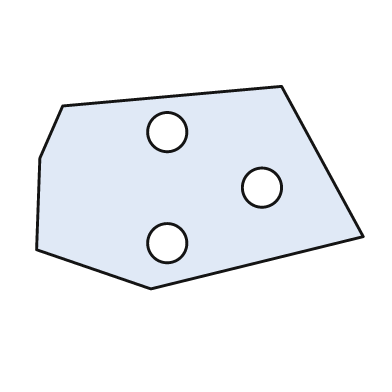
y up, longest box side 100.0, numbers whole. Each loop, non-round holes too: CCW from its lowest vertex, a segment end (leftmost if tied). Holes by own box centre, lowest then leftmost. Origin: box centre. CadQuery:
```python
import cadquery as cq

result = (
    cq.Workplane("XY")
    .moveTo(-15.0, -31.0)
    .lineTo(50.0, -15.0)
    .lineTo(25.0, 31.0)
    .lineTo(-42.0, 25.0)
    .lineTo(-49.0, 9.0)
    .lineTo(-50.0, -19.0)
    .close()
    .moveTo(-10.0, -17.0)
    .circle(6.0)
    .moveTo(19.0, 0.0)
    .circle(6.0)
    .moveTo(-10.0, 17.0)
    .circle(6.0)
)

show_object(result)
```